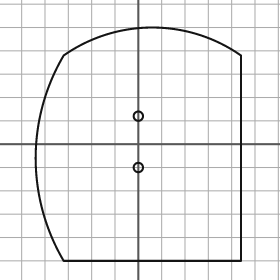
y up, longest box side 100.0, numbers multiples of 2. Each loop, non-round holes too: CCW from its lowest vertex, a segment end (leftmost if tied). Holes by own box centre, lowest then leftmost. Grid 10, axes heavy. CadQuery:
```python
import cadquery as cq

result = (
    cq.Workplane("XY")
    .moveTo(-32.0, -50.0)
    .lineTo(44.0, -50.0)
    .lineTo(44.0, 38.0)
    .threePointArc((6.0, 50.0), (-32.0, 38.0))
    .threePointArc((-44.0, -6.0), (-32.0, -50.0))
    .close()
    .moveTo(0.0, -10.0)
    .circle(2.0)
    .moveTo(0.0, 12.0)
    .circle(2.0)
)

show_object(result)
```